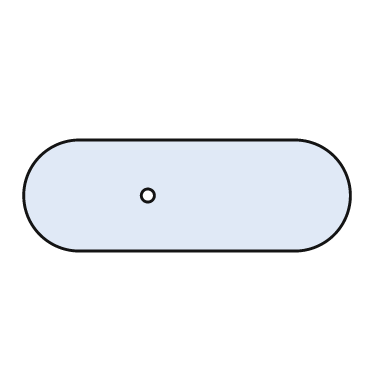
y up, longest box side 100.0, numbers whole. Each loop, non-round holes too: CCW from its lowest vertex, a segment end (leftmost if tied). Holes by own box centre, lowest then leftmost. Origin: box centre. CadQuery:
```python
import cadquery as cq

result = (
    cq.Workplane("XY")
    .moveTo(-33.0, -17.0)
    .lineTo(33.0, -17.0)
    .threePointArc((50.0, 0.0), (33.0, 17.0))
    .lineTo(-33.0, 17.0)
    .threePointArc((-50.0, 0.0), (-33.0, -17.0))
    .close()
    .moveTo(-12.0, 0.0)
    .circle(2.0)
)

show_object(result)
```